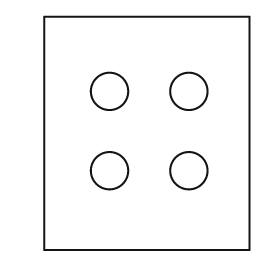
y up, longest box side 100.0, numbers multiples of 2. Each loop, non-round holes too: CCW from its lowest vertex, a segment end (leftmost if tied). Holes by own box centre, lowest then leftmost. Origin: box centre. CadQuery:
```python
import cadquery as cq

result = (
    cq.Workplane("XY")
    .moveTo(-44.0, -50.0)
    .lineTo(44.0, -50.0)
    .lineTo(44.0, 50.0)
    .lineTo(-44.0, 50.0)
    .close()
    .moveTo(-16.0, -16.0)
    .circle(8.0)
    .moveTo(18.0, -16.0)
    .circle(8.0)
    .moveTo(-16.0, 18.0)
    .circle(8.0)
    .moveTo(18.0, 18.0)
    .circle(8.0)
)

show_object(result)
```